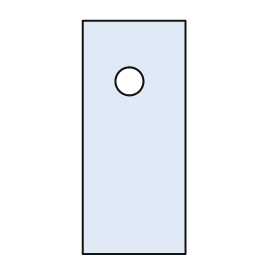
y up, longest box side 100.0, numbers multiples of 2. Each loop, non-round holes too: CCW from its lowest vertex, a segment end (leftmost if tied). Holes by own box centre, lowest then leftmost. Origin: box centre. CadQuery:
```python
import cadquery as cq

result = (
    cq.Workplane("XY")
    .moveTo(-22.0, -50.0)
    .lineTo(22.0, -50.0)
    .lineTo(22.0, 50.0)
    .lineTo(-22.0, 50.0)
    .close()
    .moveTo(-2.0, 24.0)
    .circle(6.0)
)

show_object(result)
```